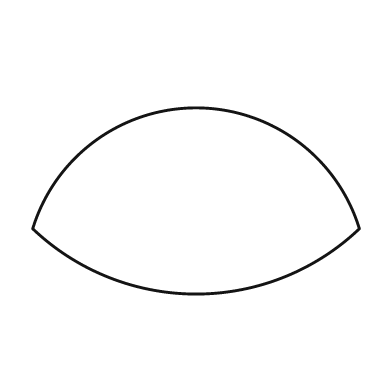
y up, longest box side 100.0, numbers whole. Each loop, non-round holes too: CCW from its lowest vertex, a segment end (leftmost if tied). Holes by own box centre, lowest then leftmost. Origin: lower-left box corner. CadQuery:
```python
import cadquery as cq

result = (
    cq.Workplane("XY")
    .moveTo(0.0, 20.0)
    .threePointArc((50.0, 0.0), (100.0, 20.0))
    .threePointArc((50.0, 57.0), (0.0, 20.0))
    .close()
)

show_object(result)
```